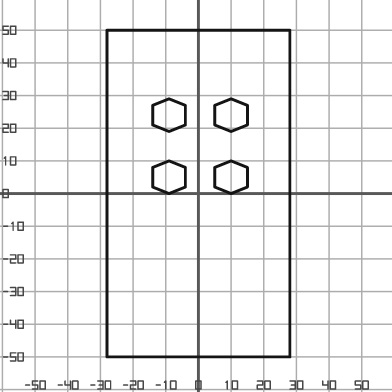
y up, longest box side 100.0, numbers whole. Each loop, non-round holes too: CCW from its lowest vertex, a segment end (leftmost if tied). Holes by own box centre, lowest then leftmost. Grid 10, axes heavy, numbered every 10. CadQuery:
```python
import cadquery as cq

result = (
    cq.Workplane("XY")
    .moveTo(-28.0, -50.0)
    .lineTo(28.0, -50.0)
    .lineTo(28.0, 50.0)
    .lineTo(-28.0, 50.0)
    .close()
    .moveTo(-9.0, 0.0)
    .lineTo(-4.0, 2.0)
    .lineTo(-4.0, 8.0)
    .lineTo(-9.0, 10.0)
    .lineTo(-14.0, 8.0)
    .lineTo(-14.0, 2.0)
    .close()
    .moveTo(10.0, 0.0)
    .lineTo(15.0, 2.0)
    .lineTo(15.0, 8.0)
    .lineTo(10.0, 10.0)
    .lineTo(5.0, 8.0)
    .lineTo(5.0, 2.0)
    .close()
    .moveTo(-9.0, 19.0)
    .lineTo(-4.0, 21.0)
    .lineTo(-4.0, 27.0)
    .lineTo(-9.0, 29.0)
    .lineTo(-14.0, 27.0)
    .lineTo(-14.0, 21.0)
    .close()
    .moveTo(10.0, 19.0)
    .lineTo(15.0, 21.0)
    .lineTo(15.0, 27.0)
    .lineTo(10.0, 29.0)
    .lineTo(5.0, 27.0)
    .lineTo(5.0, 21.0)
    .close()
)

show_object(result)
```